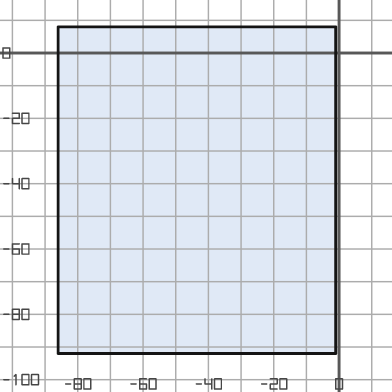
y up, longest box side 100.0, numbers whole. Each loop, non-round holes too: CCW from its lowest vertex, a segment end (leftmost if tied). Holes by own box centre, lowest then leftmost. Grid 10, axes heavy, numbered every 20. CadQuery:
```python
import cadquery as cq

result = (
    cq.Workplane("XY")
    .moveTo(-86.0, -92.0)
    .lineTo(-1.0, -92.0)
    .lineTo(-1.0, 8.0)
    .lineTo(-86.0, 8.0)
    .close()
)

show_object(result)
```